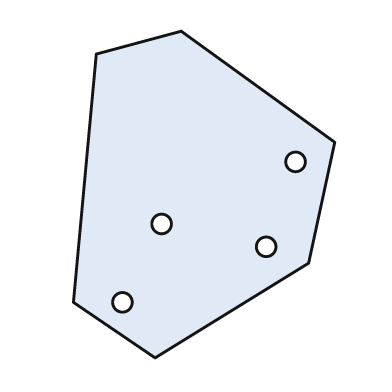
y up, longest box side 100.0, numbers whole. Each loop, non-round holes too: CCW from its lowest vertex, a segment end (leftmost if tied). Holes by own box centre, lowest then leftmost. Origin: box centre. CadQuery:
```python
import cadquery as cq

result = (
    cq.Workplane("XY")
    .moveTo(-15.0, -50.0)
    .lineTo(32.0, -21.0)
    .lineTo(40.0, 16.0)
    .lineTo(-7.0, 50.0)
    .lineTo(-33.0, 43.0)
    .lineTo(-40.0, -33.0)
    .close()
    .moveTo(-25.0, -33.0)
    .circle(3.0)
    .moveTo(19.0, -16.0)
    .circle(3.0)
    .moveTo(-13.0, -9.0)
    .circle(3.0)
    .moveTo(28.0, 10.0)
    .circle(3.0)
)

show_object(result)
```